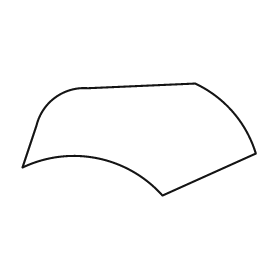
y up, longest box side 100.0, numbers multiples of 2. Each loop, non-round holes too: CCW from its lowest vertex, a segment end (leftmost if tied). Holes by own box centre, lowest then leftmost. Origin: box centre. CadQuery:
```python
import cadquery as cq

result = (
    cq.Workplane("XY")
    .moveTo(10.0, -24.0)
    .lineTo(50.0, -6.0)
    .threePointArc((40.0, 12.0), (24.0, 24.0))
    .lineTo(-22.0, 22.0)
    .threePointArc((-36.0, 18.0), (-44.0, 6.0))
    .lineTo(-50.0, -12.0)
    .threePointArc((-18.0, -8.0), (10.0, -24.0))
    .close()
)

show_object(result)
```